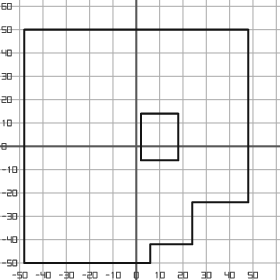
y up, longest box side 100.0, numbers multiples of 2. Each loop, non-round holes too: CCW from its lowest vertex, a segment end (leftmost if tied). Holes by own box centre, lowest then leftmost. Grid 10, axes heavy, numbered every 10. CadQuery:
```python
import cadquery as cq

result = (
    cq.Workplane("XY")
    .moveTo(-48.0, -50.0)
    .lineTo(6.0, -50.0)
    .lineTo(6.0, -42.0)
    .lineTo(24.0, -42.0)
    .lineTo(24.0, -24.0)
    .lineTo(48.0, -24.0)
    .lineTo(48.0, 50.0)
    .lineTo(-48.0, 50.0)
    .close()
    .moveTo(2.0, -6.0)
    .lineTo(18.0, -6.0)
    .lineTo(18.0, 14.0)
    .lineTo(2.0, 14.0)
    .close()
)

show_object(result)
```